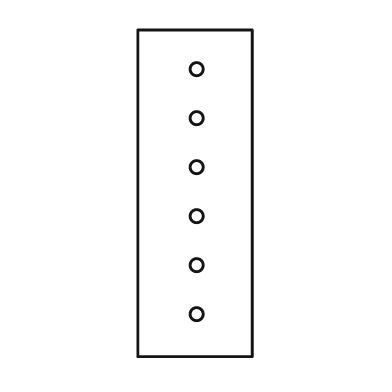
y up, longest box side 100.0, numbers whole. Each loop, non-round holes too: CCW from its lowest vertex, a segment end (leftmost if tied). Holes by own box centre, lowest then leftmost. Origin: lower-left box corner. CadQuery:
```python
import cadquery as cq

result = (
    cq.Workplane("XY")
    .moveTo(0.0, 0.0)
    .lineTo(35.0, 0.0)
    .lineTo(35.0, 100.0)
    .lineTo(0.0, 100.0)
    .close()
    .moveTo(18.0, 13.0)
    .circle(2.0)
    .moveTo(18.0, 28.0)
    .circle(2.0)
    .moveTo(18.0, 43.0)
    .circle(2.0)
    .moveTo(18.0, 58.0)
    .circle(2.0)
    .moveTo(18.0, 73.0)
    .circle(2.0)
    .moveTo(18.0, 88.0)
    .circle(2.0)
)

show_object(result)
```